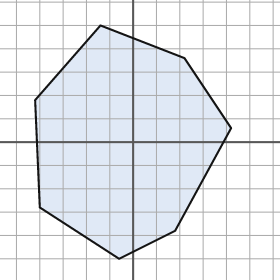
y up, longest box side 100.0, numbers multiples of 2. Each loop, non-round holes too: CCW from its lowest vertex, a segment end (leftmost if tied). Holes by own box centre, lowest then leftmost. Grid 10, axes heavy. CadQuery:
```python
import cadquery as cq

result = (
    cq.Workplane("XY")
    .moveTo(-6.0, -50.0)
    .lineTo(18.0, -38.0)
    .lineTo(42.0, 6.0)
    .lineTo(22.0, 36.0)
    .lineTo(-14.0, 50.0)
    .lineTo(-42.0, 18.0)
    .lineTo(-40.0, -28.0)
    .close()
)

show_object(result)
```